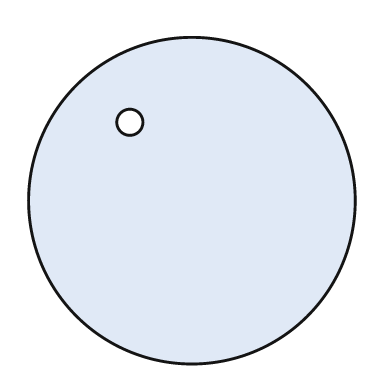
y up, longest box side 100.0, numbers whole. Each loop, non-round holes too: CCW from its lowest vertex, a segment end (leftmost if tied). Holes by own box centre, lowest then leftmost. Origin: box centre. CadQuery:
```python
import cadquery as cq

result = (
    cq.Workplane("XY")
    .moveTo(0.0, 0.0)
    .circle(50.0)
    .moveTo(-19.0, 24.0)
    .circle(4.0)
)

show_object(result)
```